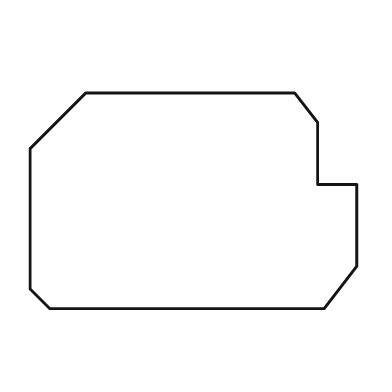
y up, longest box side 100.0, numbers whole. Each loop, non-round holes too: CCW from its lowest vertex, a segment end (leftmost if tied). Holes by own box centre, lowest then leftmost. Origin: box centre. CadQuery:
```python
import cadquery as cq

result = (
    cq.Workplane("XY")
    .moveTo(-44.0, -33.0)
    .lineTo(40.0, -33.0)
    .lineTo(50.0, -20.0)
    .lineTo(50.0, 5.0)
    .lineTo(38.0, 5.0)
    .lineTo(38.0, 24.0)
    .lineTo(31.0, 33.0)
    .lineTo(-33.0, 33.0)
    .lineTo(-50.0, 16.0)
    .lineTo(-50.0, -27.0)
    .close()
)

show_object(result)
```